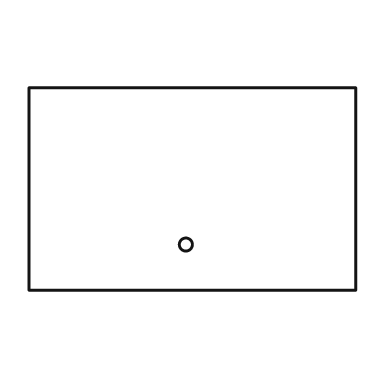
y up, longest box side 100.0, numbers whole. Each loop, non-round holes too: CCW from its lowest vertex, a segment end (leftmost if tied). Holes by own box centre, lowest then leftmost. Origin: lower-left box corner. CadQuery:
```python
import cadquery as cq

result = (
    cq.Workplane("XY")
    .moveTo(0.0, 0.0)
    .lineTo(100.0, 0.0)
    .lineTo(100.0, 62.0)
    .lineTo(0.0, 62.0)
    .close()
    .moveTo(48.0, 14.0)
    .circle(2.0)
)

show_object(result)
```